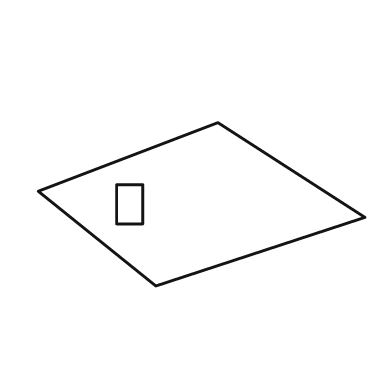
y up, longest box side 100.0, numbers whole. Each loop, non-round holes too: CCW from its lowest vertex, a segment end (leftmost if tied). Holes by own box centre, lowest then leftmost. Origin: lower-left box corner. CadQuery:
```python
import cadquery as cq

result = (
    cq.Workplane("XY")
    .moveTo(36.0, 0.0)
    .lineTo(100.0, 21.0)
    .lineTo(55.0, 50.0)
    .lineTo(0.0, 29.0)
    .close()
    .moveTo(24.0, 19.0)
    .lineTo(32.0, 19.0)
    .lineTo(32.0, 31.0)
    .lineTo(24.0, 31.0)
    .close()
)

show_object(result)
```